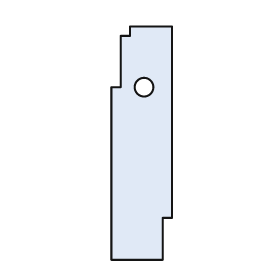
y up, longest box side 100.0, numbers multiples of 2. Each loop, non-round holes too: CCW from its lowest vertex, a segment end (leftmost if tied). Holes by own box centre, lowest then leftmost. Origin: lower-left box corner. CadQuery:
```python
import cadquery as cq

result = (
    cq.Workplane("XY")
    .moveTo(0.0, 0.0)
    .lineTo(22.0, 0.0)
    .lineTo(22.0, 18.0)
    .lineTo(26.0, 18.0)
    .lineTo(26.0, 100.0)
    .lineTo(8.0, 100.0)
    .lineTo(8.0, 96.0)
    .lineTo(4.0, 96.0)
    .lineTo(4.0, 74.0)
    .lineTo(0.0, 74.0)
    .close()
    .moveTo(14.0, 74.0)
    .circle(4.0)
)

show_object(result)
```